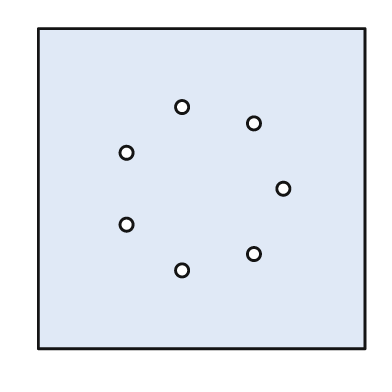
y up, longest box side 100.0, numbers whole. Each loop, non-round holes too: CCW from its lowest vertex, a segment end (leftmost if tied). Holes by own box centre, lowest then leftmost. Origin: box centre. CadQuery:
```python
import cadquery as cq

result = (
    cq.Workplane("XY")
    .moveTo(-50.0, -49.0)
    .lineTo(50.0, -49.0)
    .lineTo(50.0, 49.0)
    .lineTo(-50.0, 49.0)
    .close()
    .moveTo(-6.0, -25.0)
    .circle(2.0)
    .moveTo(16.0, -20.0)
    .circle(2.0)
    .moveTo(-23.0, -11.0)
    .circle(2.0)
    .moveTo(25.0, 0.0)
    .circle(2.0)
    .moveTo(-23.0, 11.0)
    .circle(2.0)
    .moveTo(16.0, 20.0)
    .circle(2.0)
    .moveTo(-6.0, 25.0)
    .circle(2.0)
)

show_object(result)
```